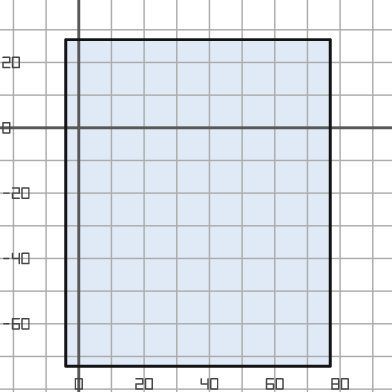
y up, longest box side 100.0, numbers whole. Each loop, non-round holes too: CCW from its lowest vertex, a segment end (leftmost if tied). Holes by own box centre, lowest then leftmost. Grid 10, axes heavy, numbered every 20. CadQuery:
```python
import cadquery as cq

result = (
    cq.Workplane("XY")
    .moveTo(-4.0, -73.0)
    .lineTo(77.0, -73.0)
    .lineTo(77.0, 27.0)
    .lineTo(-4.0, 27.0)
    .close()
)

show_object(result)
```